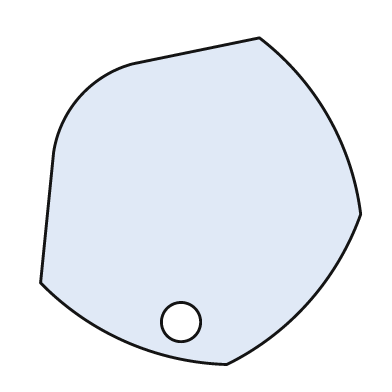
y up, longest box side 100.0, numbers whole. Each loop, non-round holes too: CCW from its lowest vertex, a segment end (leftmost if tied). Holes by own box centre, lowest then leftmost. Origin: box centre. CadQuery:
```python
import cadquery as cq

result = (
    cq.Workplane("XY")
    .moveTo(8.0, -50.0)
    .threePointArc((33.0, -31.0), (49.0, -4.0))
    .threePointArc((39.0, 26.0), (18.0, 50.0))
    .lineTo(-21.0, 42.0)
    .threePointArc((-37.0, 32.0), (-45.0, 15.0))
    .lineTo(-49.0, -25.0)
    .threePointArc((-23.0, -43.0), (8.0, -50.0))
    .close()
    .moveTo(-6.0, -37.0)
    .circle(6.0)
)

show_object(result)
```